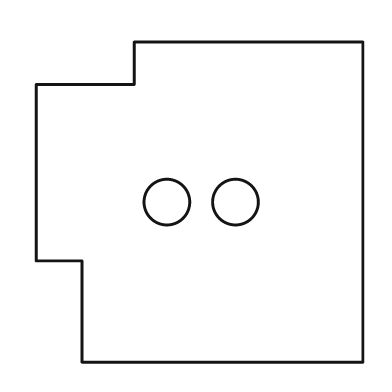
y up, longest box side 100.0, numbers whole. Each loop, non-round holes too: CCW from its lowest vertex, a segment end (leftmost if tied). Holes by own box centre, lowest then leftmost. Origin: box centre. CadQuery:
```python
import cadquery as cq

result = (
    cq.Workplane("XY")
    .moveTo(-36.0, -49.0)
    .lineTo(50.0, -49.0)
    .lineTo(50.0, 49.0)
    .lineTo(-20.0, 49.0)
    .lineTo(-20.0, 36.0)
    .lineTo(-50.0, 36.0)
    .lineTo(-50.0, -18.0)
    .lineTo(-36.0, -18.0)
    .close()
    .moveTo(-10.0, 0.0)
    .circle(7.0)
    .moveTo(11.0, 0.0)
    .circle(7.0)
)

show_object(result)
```